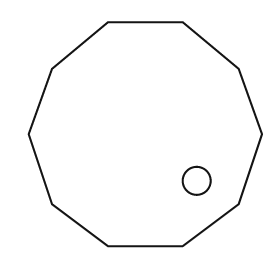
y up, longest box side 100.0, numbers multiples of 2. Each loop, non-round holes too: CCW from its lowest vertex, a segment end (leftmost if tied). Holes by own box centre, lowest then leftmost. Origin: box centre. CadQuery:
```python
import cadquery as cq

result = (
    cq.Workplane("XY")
    .moveTo(-16.0, -48.0)
    .lineTo(16.0, -48.0)
    .lineTo(40.0, -30.0)
    .lineTo(50.0, 0.0)
    .lineTo(40.0, 28.0)
    .lineTo(16.0, 48.0)
    .lineTo(-16.0, 48.0)
    .lineTo(-40.0, 28.0)
    .lineTo(-50.0, 0.0)
    .lineTo(-40.0, -30.0)
    .close()
    .moveTo(22.0, -20.0)
    .circle(6.0)
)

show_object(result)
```